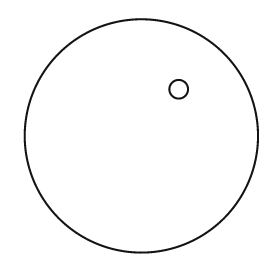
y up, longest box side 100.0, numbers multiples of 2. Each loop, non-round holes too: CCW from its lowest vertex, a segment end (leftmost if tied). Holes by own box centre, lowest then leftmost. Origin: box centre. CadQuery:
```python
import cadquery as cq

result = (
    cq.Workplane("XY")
    .moveTo(0.0, 0.0)
    .circle(50.0)
    .moveTo(16.0, 20.0)
    .circle(4.0)
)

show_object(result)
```